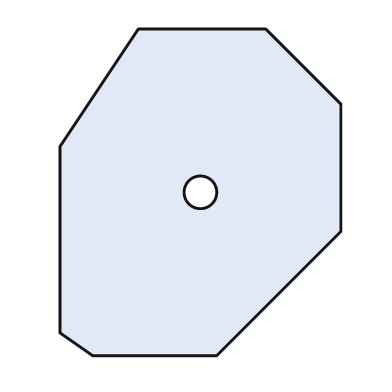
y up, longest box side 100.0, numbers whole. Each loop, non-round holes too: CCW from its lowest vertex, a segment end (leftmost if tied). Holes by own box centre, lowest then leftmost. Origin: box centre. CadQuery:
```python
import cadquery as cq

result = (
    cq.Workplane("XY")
    .moveTo(-33.0, -50.0)
    .lineTo(5.0, -50.0)
    .lineTo(43.0, -12.0)
    .lineTo(43.0, 27.0)
    .lineTo(20.0, 50.0)
    .lineTo(-19.0, 50.0)
    .lineTo(-43.0, 14.0)
    .lineTo(-43.0, -43.0)
    .close()
    .moveTo(0.0, 0.0)
    .circle(5.0)
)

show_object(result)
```